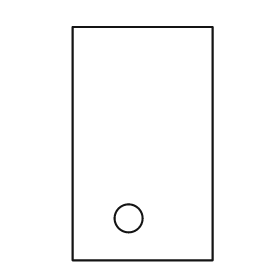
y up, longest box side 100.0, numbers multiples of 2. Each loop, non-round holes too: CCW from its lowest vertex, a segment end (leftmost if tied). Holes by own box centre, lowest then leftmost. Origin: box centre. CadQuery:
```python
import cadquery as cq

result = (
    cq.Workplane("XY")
    .moveTo(-30.0, -50.0)
    .lineTo(30.0, -50.0)
    .lineTo(30.0, 50.0)
    .lineTo(-30.0, 50.0)
    .close()
    .moveTo(-6.0, -32.0)
    .circle(6.0)
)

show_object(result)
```